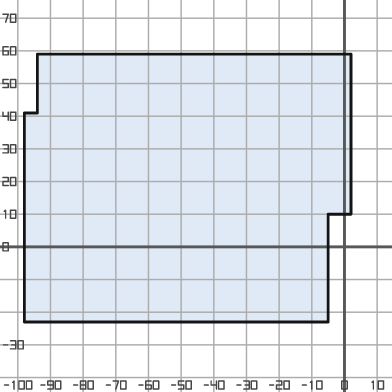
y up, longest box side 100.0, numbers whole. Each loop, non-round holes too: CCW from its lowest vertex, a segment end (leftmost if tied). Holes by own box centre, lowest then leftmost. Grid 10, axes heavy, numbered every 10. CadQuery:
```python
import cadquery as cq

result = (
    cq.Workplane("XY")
    .moveTo(-98.0, -23.0)
    .lineTo(-5.0, -23.0)
    .lineTo(-5.0, 10.0)
    .lineTo(2.0, 10.0)
    .lineTo(2.0, 59.0)
    .lineTo(-94.0, 59.0)
    .lineTo(-94.0, 41.0)
    .lineTo(-98.0, 41.0)
    .close()
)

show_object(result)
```